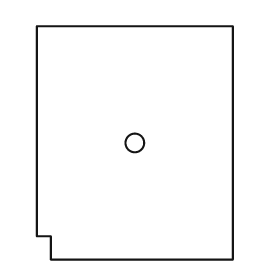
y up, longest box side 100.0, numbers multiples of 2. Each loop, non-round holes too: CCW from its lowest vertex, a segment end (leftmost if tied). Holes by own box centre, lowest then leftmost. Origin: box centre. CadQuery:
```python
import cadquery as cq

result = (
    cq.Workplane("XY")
    .moveTo(-36.0, -50.0)
    .lineTo(42.0, -50.0)
    .lineTo(42.0, 50.0)
    .lineTo(-42.0, 50.0)
    .lineTo(-42.0, -40.0)
    .lineTo(-36.0, -40.0)
    .close()
    .moveTo(0.0, 0.0)
    .circle(4.0)
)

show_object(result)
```